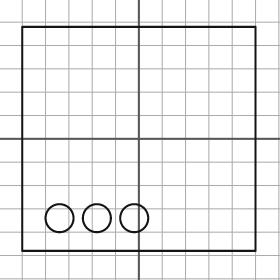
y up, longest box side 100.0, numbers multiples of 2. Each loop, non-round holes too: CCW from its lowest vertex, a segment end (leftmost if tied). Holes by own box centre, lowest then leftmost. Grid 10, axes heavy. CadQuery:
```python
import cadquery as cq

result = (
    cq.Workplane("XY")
    .moveTo(-50.0, -48.0)
    .lineTo(50.0, -48.0)
    .lineTo(50.0, 48.0)
    .lineTo(-50.0, 48.0)
    .close()
    .moveTo(-34.0, -34.0)
    .circle(6.0)
    .moveTo(-18.0, -34.0)
    .circle(6.0)
    .moveTo(-2.0, -34.0)
    .circle(6.0)
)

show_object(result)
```